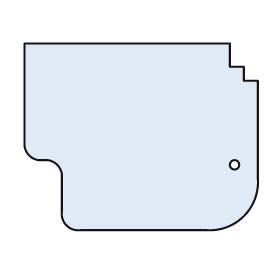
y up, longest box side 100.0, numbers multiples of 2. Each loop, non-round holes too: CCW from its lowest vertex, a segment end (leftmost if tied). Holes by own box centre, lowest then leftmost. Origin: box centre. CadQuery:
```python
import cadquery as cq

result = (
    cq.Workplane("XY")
    .moveTo(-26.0, -40.0)
    .lineTo(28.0, -40.0)
    .threePointArc((44.0, -34.0), (50.0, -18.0))
    .lineTo(50.0, 24.0)
    .lineTo(44.0, 24.0)
    .lineTo(44.0, 30.0)
    .lineTo(38.0, 30.0)
    .lineTo(38.0, 40.0)
    .lineTo(-50.0, 40.0)
    .lineTo(-50.0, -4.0)
    .threePointArc((-48.0, -8.0), (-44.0, -10.0))
    .lineTo(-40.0, -10.0)
    .threePointArc((-36.0, -12.0), (-34.0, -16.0))
    .lineTo(-34.0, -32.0)
    .threePointArc((-32.0, -38.0), (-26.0, -40.0))
    .close()
    .moveTo(40.0, -12.0)
    .circle(2.0)
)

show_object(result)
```